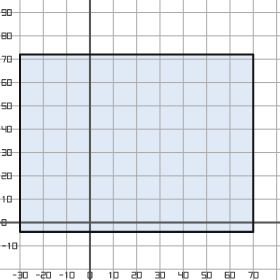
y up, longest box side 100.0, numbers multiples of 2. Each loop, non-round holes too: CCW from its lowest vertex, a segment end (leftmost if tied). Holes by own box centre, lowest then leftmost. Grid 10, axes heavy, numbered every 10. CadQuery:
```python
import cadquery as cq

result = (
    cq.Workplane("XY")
    .moveTo(-30.0, -4.0)
    .lineTo(70.0, -4.0)
    .lineTo(70.0, 72.0)
    .lineTo(-30.0, 72.0)
    .close()
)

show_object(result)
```